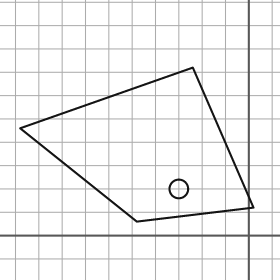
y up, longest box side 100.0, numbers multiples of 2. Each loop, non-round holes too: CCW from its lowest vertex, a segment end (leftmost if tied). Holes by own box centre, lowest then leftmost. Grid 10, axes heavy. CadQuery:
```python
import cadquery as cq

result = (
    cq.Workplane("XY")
    .moveTo(-48.0, 6.0)
    .lineTo(2.0, 12.0)
    .lineTo(-24.0, 72.0)
    .lineTo(-98.0, 46.0)
    .close()
    .moveTo(-30.0, 20.0)
    .circle(4.0)
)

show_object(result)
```